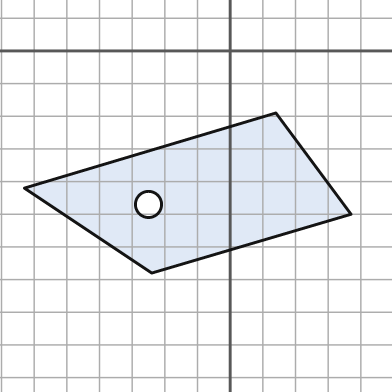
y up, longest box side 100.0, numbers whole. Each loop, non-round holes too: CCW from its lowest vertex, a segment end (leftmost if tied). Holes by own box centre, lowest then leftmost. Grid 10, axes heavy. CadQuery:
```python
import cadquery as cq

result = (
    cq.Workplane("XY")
    .moveTo(-24.0, -68.0)
    .lineTo(37.0, -50.0)
    .lineTo(14.0, -19.0)
    .lineTo(-63.0, -42.0)
    .close()
    .moveTo(-25.0, -47.0)
    .circle(4.0)
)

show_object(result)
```